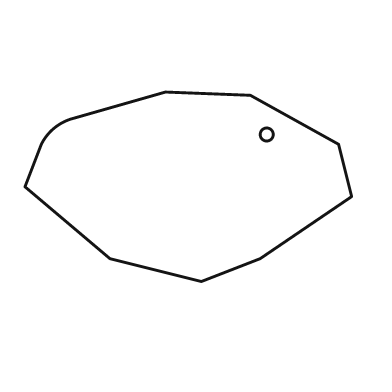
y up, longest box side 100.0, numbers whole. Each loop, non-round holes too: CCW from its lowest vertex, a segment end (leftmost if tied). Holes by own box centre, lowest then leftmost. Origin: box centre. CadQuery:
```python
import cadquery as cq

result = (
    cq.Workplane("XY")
    .moveTo(4.0, -29.0)
    .lineTo(22.0, -22.0)
    .lineTo(50.0, -3.0)
    .lineTo(46.0, 13.0)
    .lineTo(19.0, 28.0)
    .lineTo(-7.0, 29.0)
    .lineTo(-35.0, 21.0)
    .threePointArc((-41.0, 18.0), (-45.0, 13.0))
    .lineTo(-50.0, 0.0)
    .lineTo(-24.0, -22.0)
    .close()
    .moveTo(24.0, 16.0)
    .circle(2.0)
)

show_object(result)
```